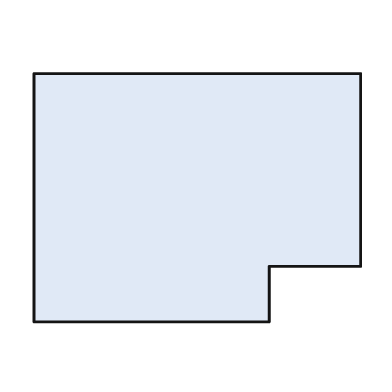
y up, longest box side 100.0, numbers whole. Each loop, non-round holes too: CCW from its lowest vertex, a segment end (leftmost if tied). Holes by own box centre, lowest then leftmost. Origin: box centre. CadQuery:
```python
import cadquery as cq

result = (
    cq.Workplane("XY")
    .moveTo(-50.0, -38.0)
    .lineTo(22.0, -38.0)
    .lineTo(22.0, -21.0)
    .lineTo(50.0, -21.0)
    .lineTo(50.0, 38.0)
    .lineTo(-50.0, 38.0)
    .close()
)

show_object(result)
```